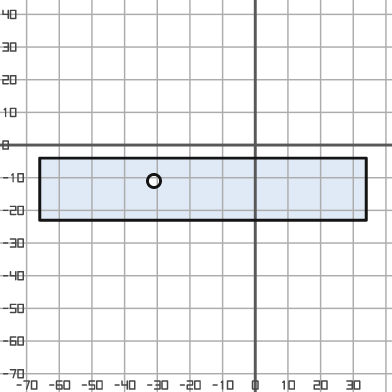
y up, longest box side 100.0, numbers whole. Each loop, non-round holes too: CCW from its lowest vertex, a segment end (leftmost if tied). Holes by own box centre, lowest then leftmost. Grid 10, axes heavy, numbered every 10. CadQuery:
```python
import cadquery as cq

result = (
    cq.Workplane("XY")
    .moveTo(-66.0, -23.0)
    .lineTo(34.0, -23.0)
    .lineTo(34.0, -4.0)
    .lineTo(-66.0, -4.0)
    .close()
    .moveTo(-31.0, -11.0)
    .circle(2.0)
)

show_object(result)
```